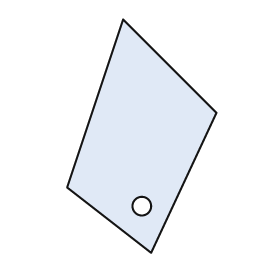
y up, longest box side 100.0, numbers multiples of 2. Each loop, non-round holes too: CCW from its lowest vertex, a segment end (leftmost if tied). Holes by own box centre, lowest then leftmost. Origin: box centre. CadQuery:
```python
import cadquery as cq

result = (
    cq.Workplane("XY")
    .moveTo(4.0, -50.0)
    .lineTo(32.0, 10.0)
    .lineTo(-8.0, 50.0)
    .lineTo(-32.0, -22.0)
    .close()
    .moveTo(0.0, -30.0)
    .circle(4.0)
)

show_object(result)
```